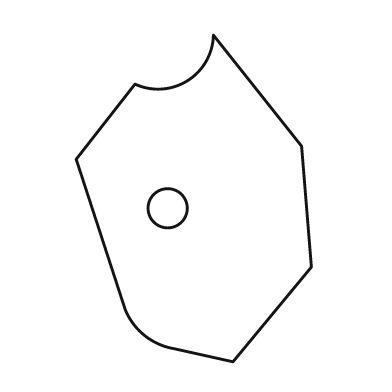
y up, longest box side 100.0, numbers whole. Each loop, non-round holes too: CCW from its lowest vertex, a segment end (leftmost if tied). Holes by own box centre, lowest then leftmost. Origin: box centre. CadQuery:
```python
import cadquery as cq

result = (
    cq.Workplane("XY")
    .moveTo(12.0, -50.0)
    .lineTo(36.0, -21.0)
    .lineTo(33.0, 16.0)
    .lineTo(6.0, 50.0)
    .threePointArc((-2.0, 36.0), (-18.0, 35.0))
    .lineTo(-36.0, 12.0)
    .lineTo(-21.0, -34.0)
    .threePointArc((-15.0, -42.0), (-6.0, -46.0))
    .close()
    .moveTo(-8.0, -3.0)
    .circle(6.0)
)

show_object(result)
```